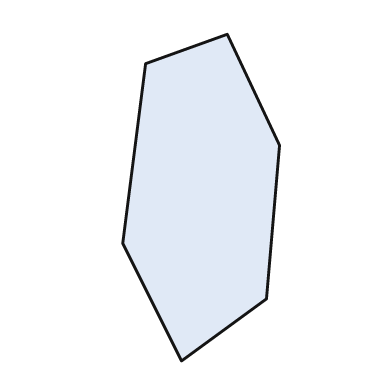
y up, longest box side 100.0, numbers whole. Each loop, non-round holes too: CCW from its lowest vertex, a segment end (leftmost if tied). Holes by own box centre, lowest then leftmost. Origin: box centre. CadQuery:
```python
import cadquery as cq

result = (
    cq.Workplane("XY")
    .moveTo(-6.0, -50.0)
    .lineTo(20.0, -31.0)
    .lineTo(24.0, 16.0)
    .lineTo(8.0, 50.0)
    .lineTo(-17.0, 41.0)
    .lineTo(-24.0, -14.0)
    .close()
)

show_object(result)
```